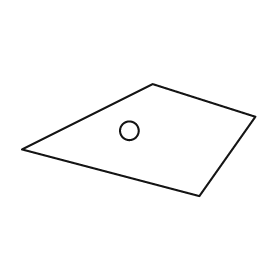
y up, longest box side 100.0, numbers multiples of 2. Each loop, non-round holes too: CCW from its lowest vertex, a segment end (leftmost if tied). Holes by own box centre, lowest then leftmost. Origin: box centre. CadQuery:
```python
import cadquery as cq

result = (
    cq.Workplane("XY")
    .moveTo(26.0, -24.0)
    .lineTo(50.0, 10.0)
    .lineTo(6.0, 24.0)
    .lineTo(-50.0, -4.0)
    .close()
    .moveTo(-4.0, 4.0)
    .circle(4.0)
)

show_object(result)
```